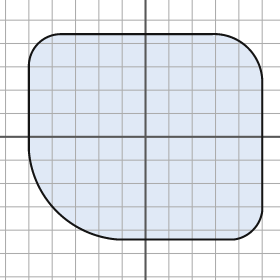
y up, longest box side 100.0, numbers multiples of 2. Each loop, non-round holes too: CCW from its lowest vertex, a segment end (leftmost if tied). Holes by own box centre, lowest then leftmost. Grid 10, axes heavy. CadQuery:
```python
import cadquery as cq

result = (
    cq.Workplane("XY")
    .moveTo(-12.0, -44.0)
    .lineTo(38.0, -44.0)
    .threePointArc((46.0, -40.0), (50.0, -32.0))
    .lineTo(50.0, 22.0)
    .threePointArc((44.0, 38.0), (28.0, 44.0))
    .lineTo(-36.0, 44.0)
    .threePointArc((-46.0, 40.0), (-50.0, 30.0))
    .lineTo(-50.0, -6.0)
    .threePointArc((-38.0, -32.0), (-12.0, -44.0))
    .close()
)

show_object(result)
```